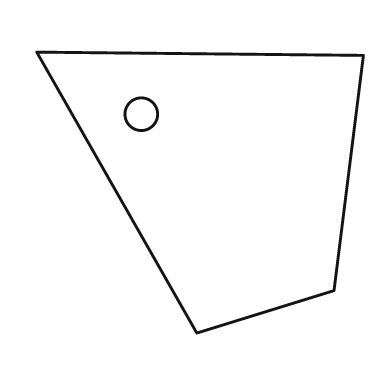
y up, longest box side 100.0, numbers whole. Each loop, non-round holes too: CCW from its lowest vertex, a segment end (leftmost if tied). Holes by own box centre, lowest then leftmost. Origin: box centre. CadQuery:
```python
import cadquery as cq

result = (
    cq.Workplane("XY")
    .moveTo(-1.0, -43.0)
    .lineTo(41.0, -30.0)
    .lineTo(50.0, 42.0)
    .lineTo(-50.0, 43.0)
    .close()
    .moveTo(-18.0, 24.0)
    .circle(5.0)
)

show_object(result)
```